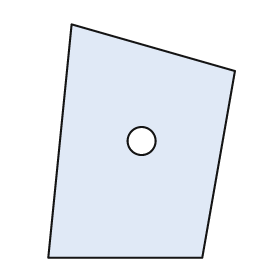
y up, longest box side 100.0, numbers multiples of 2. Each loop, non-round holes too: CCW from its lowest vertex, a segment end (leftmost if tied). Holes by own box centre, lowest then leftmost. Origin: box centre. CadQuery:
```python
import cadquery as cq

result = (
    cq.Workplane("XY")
    .moveTo(-40.0, -50.0)
    .lineTo(26.0, -50.0)
    .lineTo(40.0, 30.0)
    .lineTo(-30.0, 50.0)
    .close()
    .moveTo(0.0, 0.0)
    .circle(6.0)
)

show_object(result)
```